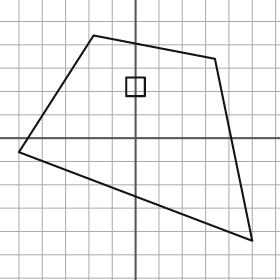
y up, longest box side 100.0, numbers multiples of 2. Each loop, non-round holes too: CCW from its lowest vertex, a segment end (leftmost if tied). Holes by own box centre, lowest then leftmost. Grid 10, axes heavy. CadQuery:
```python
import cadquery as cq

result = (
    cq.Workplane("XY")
    .moveTo(50.0, -44.0)
    .lineTo(34.0, 34.0)
    .lineTo(-18.0, 44.0)
    .lineTo(-50.0, -6.0)
    .close()
    .moveTo(-4.0, 18.0)
    .lineTo(4.0, 18.0)
    .lineTo(4.0, 26.0)
    .lineTo(-4.0, 26.0)
    .close()
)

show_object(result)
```